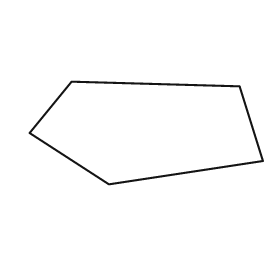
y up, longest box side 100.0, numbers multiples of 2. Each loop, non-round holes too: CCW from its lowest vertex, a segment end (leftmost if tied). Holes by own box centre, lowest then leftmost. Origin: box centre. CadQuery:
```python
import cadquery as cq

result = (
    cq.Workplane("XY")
    .moveTo(-16.0, -22.0)
    .lineTo(50.0, -12.0)
    .lineTo(40.0, 20.0)
    .lineTo(-32.0, 22.0)
    .lineTo(-50.0, 0.0)
    .close()
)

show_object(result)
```